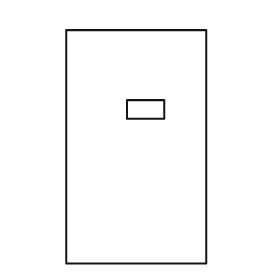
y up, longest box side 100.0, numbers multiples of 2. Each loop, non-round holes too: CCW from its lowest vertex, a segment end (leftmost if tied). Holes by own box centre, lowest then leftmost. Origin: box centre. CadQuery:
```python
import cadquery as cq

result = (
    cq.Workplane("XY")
    .moveTo(-30.0, -50.0)
    .lineTo(30.0, -50.0)
    .lineTo(30.0, 50.0)
    .lineTo(-30.0, 50.0)
    .close()
    .moveTo(-4.0, 12.0)
    .lineTo(12.0, 12.0)
    .lineTo(12.0, 20.0)
    .lineTo(-4.0, 20.0)
    .close()
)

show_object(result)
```